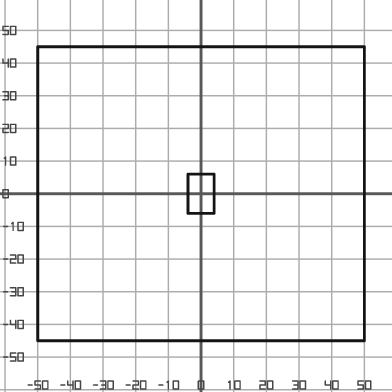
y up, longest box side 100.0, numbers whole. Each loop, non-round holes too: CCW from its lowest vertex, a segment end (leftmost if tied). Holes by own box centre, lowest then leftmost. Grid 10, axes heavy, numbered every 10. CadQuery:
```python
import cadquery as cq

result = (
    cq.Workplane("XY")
    .moveTo(-50.0, -45.0)
    .lineTo(50.0, -45.0)
    .lineTo(50.0, 45.0)
    .lineTo(-50.0, 45.0)
    .close()
    .moveTo(-4.0, -6.0)
    .lineTo(4.0, -6.0)
    .lineTo(4.0, 6.0)
    .lineTo(-4.0, 6.0)
    .close()
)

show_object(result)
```